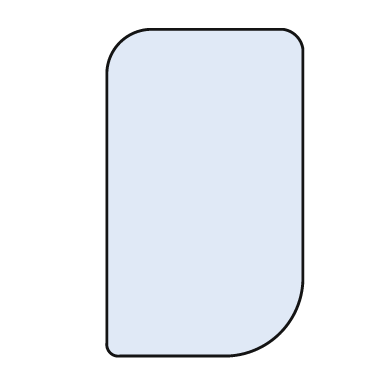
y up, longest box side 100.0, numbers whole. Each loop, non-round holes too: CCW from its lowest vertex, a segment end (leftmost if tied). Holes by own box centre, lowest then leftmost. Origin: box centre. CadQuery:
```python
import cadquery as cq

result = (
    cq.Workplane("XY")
    .moveTo(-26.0, -50.0)
    .lineTo(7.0, -50.0)
    .threePointArc((23.0, -43.0), (30.0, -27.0))
    .lineTo(30.0, 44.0)
    .threePointArc((28.0, 48.0), (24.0, 50.0))
    .lineTo(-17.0, 50.0)
    .threePointArc((-26.0, 46.0), (-30.0, 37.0))
    .lineTo(-30.0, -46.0)
    .threePointArc((-29.0, -49.0), (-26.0, -50.0))
    .close()
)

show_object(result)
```